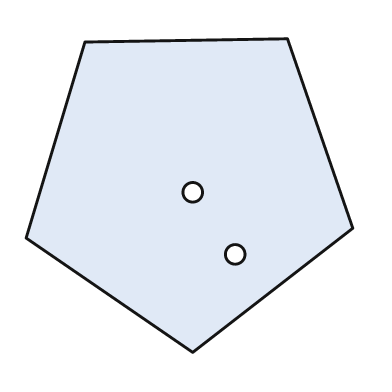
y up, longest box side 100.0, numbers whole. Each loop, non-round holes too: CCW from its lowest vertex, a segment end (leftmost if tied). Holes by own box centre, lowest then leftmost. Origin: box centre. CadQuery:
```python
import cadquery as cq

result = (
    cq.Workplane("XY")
    .moveTo(1.0, -48.0)
    .lineTo(50.0, -10.0)
    .lineTo(30.0, 48.0)
    .lineTo(-32.0, 47.0)
    .lineTo(-50.0, -13.0)
    .close()
    .moveTo(14.0, -18.0)
    .circle(3.0)
    .moveTo(1.0, 1.0)
    .circle(3.0)
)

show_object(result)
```